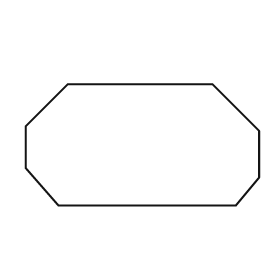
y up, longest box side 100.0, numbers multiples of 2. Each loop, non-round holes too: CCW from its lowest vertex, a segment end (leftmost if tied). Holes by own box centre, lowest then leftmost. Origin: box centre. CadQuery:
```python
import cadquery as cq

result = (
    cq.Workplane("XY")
    .moveTo(-36.0, -26.0)
    .lineTo(40.0, -26.0)
    .lineTo(50.0, -14.0)
    .lineTo(50.0, 6.0)
    .lineTo(30.0, 26.0)
    .lineTo(-32.0, 26.0)
    .lineTo(-50.0, 8.0)
    .lineTo(-50.0, -10.0)
    .close()
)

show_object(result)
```